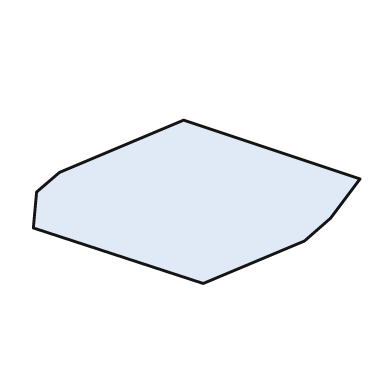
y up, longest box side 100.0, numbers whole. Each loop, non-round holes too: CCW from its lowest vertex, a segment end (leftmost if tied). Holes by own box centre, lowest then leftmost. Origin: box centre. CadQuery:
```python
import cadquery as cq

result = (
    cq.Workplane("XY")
    .moveTo(2.0, -25.0)
    .lineTo(33.0, -12.0)
    .lineTo(41.0, -5.0)
    .lineTo(50.0, 7.0)
    .lineTo(-4.0, 25.0)
    .lineTo(-42.0, 9.0)
    .lineTo(-49.0, 3.0)
    .lineTo(-50.0, -8.0)
    .close()
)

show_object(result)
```